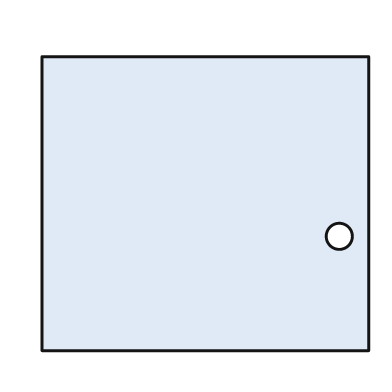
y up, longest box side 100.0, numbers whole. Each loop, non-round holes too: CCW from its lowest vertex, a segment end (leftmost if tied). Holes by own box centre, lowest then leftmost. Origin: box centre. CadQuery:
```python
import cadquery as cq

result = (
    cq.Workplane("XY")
    .moveTo(-50.0, -45.0)
    .lineTo(50.0, -45.0)
    .lineTo(50.0, 45.0)
    .lineTo(-50.0, 45.0)
    .close()
    .moveTo(41.0, -10.0)
    .circle(4.0)
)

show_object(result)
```